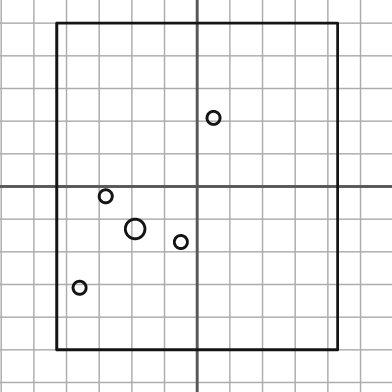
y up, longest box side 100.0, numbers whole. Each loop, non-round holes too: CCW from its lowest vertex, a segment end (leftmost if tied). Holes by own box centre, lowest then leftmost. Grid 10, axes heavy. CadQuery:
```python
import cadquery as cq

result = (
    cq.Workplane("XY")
    .moveTo(-43.0, -50.0)
    .lineTo(43.0, -50.0)
    .lineTo(43.0, 50.0)
    .lineTo(-43.0, 50.0)
    .close()
    .moveTo(-36.0, -31.0)
    .circle(2.0)
    .moveTo(-5.0, -17.0)
    .circle(2.0)
    .moveTo(-19.0, -13.0)
    .circle(3.0)
    .moveTo(-28.0, -3.0)
    .circle(2.0)
    .moveTo(5.0, 21.0)
    .circle(2.0)
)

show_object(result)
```